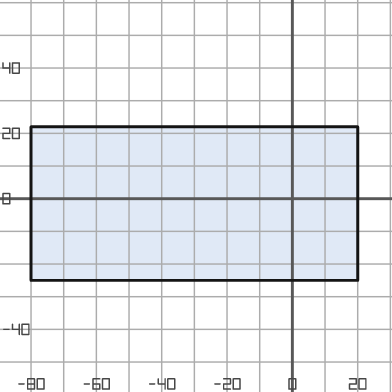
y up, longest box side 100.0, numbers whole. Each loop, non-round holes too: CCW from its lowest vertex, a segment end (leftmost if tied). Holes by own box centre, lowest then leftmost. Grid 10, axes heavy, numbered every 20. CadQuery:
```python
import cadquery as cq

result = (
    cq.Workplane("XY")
    .moveTo(-80.0, -25.0)
    .lineTo(20.0, -25.0)
    .lineTo(20.0, 22.0)
    .lineTo(-80.0, 22.0)
    .close()
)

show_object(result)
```